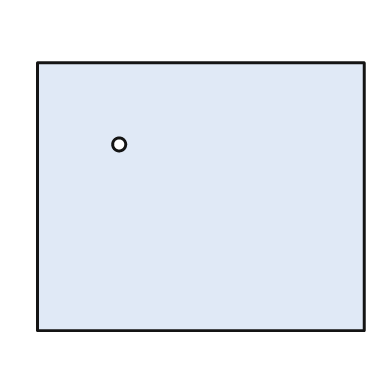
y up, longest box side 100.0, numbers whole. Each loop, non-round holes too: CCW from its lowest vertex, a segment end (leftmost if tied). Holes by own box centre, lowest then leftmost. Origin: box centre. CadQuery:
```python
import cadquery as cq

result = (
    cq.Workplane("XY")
    .moveTo(-50.0, -41.0)
    .lineTo(50.0, -41.0)
    .lineTo(50.0, 41.0)
    .lineTo(-50.0, 41.0)
    .close()
    .moveTo(-25.0, 16.0)
    .circle(2.0)
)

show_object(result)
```